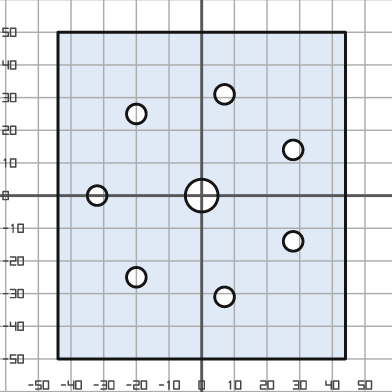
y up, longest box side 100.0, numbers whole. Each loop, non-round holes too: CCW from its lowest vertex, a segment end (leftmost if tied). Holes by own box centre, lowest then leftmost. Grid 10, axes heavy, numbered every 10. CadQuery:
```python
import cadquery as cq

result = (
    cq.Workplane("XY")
    .moveTo(-44.0, -50.0)
    .lineTo(44.0, -50.0)
    .lineTo(44.0, 50.0)
    .lineTo(-44.0, 50.0)
    .close()
    .moveTo(7.0, -31.0)
    .circle(3.0)
    .moveTo(-20.0, -25.0)
    .circle(3.0)
    .moveTo(28.0, -14.0)
    .circle(3.0)
    .moveTo(-32.0, 0.0)
    .circle(3.0)
    .moveTo(0.0, 0.0)
    .circle(5.0)
    .moveTo(28.0, 14.0)
    .circle(3.0)
    .moveTo(-20.0, 25.0)
    .circle(3.0)
    .moveTo(7.0, 31.0)
    .circle(3.0)
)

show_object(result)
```